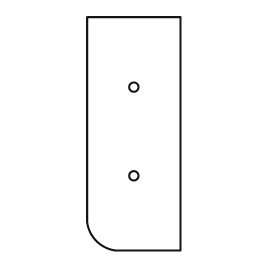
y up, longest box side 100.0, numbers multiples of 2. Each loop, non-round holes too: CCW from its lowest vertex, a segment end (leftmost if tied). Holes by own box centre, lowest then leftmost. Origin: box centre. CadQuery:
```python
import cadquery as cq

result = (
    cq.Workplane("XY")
    .moveTo(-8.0, -50.0)
    .lineTo(20.0, -50.0)
    .lineTo(20.0, 50.0)
    .lineTo(-20.0, 50.0)
    .lineTo(-20.0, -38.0)
    .threePointArc((-16.0, -46.0), (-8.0, -50.0))
    .close()
    .moveTo(0.0, -18.0)
    .circle(2.0)
    .moveTo(0.0, 20.0)
    .circle(2.0)
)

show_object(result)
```